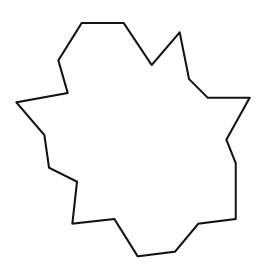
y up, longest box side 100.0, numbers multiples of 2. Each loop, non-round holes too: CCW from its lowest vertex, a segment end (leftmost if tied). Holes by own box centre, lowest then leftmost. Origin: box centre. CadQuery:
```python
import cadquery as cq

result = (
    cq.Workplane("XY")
    .moveTo(2.0, -50.0)
    .lineTo(18.0, -48.0)
    .lineTo(28.0, -36.0)
    .lineTo(44.0, -34.0)
    .lineTo(44.0, -10.0)
    .lineTo(40.0, 0.0)
    .lineTo(50.0, 18.0)
    .lineTo(32.0, 18.0)
    .lineTo(24.0, 26.0)
    .lineTo(20.0, 46.0)
    .lineTo(8.0, 32.0)
    .lineTo(-4.0, 50.0)
    .lineTo(-22.0, 50.0)
    .lineTo(-32.0, 34.0)
    .lineTo(-28.0, 20.0)
    .lineTo(-50.0, 16.0)
    .lineTo(-38.0, 2.0)
    .lineTo(-36.0, -12.0)
    .lineTo(-24.0, -18.0)
    .lineTo(-26.0, -36.0)
    .lineTo(-8.0, -34.0)
    .close()
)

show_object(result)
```